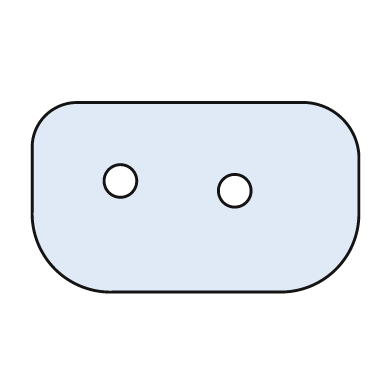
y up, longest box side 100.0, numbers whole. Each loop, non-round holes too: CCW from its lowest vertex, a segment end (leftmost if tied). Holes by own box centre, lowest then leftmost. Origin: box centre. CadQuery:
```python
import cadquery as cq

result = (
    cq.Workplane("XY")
    .moveTo(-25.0, -29.0)
    .lineTo(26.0, -29.0)
    .threePointArc((43.0, -22.0), (50.0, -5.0))
    .lineTo(50.0, 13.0)
    .threePointArc((45.0, 24.0), (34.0, 29.0))
    .lineTo(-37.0, 29.0)
    .threePointArc((-46.0, 25.0), (-50.0, 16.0))
    .lineTo(-50.0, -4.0)
    .threePointArc((-43.0, -22.0), (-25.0, -29.0))
    .close()
    .moveTo(12.0, 2.0)
    .circle(5.0)
    .moveTo(-23.0, 5.0)
    .circle(5.0)
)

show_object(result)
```